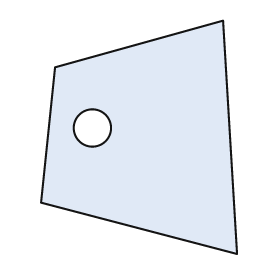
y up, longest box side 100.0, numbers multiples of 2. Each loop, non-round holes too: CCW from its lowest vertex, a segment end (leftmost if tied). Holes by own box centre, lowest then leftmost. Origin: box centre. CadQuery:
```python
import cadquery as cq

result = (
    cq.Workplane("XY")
    .moveTo(42.0, -50.0)
    .lineTo(36.0, 50.0)
    .lineTo(-36.0, 30.0)
    .lineTo(-42.0, -28.0)
    .close()
    .moveTo(-20.0, 4.0)
    .circle(8.0)
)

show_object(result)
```